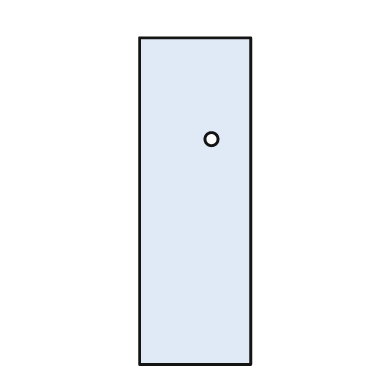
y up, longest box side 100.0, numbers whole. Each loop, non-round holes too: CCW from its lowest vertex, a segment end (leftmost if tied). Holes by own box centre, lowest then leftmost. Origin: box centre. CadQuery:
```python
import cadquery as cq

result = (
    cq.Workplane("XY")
    .moveTo(-17.0, -50.0)
    .lineTo(17.0, -50.0)
    .lineTo(17.0, 50.0)
    .lineTo(-17.0, 50.0)
    .close()
    .moveTo(5.0, 19.0)
    .circle(2.0)
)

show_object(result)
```